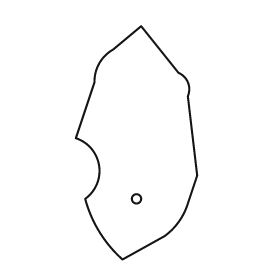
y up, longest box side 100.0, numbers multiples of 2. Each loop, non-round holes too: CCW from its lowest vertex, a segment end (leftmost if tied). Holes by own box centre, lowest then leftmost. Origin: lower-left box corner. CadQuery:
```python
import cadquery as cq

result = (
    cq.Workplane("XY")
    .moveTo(20.0, 0.0)
    .lineTo(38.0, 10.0)
    .threePointArc((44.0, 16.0), (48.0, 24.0))
    .lineTo(52.0, 36.0)
    .lineTo(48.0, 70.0)
    .threePointArc((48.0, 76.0), (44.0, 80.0))
    .lineTo(28.0, 100.0)
    .lineTo(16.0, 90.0)
    .threePointArc((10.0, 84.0), (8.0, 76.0))
    .lineTo(0.0, 52.0)
    .threePointArc((10.0, 40.0), (4.0, 26.0))
    .threePointArc((10.0, 12.0), (20.0, 0.0))
    .close()
    .moveTo(26.0, 26.0)
    .circle(2.0)
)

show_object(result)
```